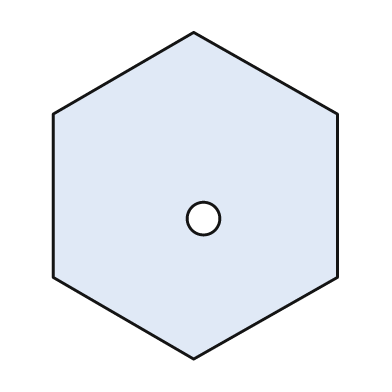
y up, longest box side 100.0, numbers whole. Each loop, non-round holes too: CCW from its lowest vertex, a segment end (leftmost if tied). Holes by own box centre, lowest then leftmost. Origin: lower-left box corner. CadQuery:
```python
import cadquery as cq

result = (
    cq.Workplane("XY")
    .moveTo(43.0, 0.0)
    .lineTo(87.0, 25.0)
    .lineTo(87.0, 75.0)
    .lineTo(43.0, 100.0)
    .lineTo(0.0, 75.0)
    .lineTo(0.0, 25.0)
    .close()
    .moveTo(46.0, 43.0)
    .circle(5.0)
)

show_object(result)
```